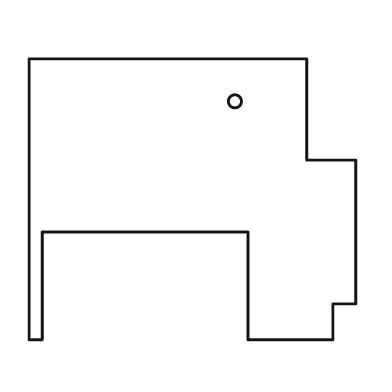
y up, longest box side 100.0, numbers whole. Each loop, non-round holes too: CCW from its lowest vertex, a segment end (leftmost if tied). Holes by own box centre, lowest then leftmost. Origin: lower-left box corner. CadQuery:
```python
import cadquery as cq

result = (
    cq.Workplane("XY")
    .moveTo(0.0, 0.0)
    .lineTo(4.0, 0.0)
    .lineTo(4.0, 33.0)
    .lineTo(67.0, 33.0)
    .lineTo(67.0, 0.0)
    .lineTo(93.0, 0.0)
    .lineTo(93.0, 11.0)
    .lineTo(100.0, 11.0)
    .lineTo(100.0, 55.0)
    .lineTo(85.0, 55.0)
    .lineTo(85.0, 86.0)
    .lineTo(0.0, 86.0)
    .close()
    .moveTo(63.0, 73.0)
    .circle(2.0)
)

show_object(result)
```